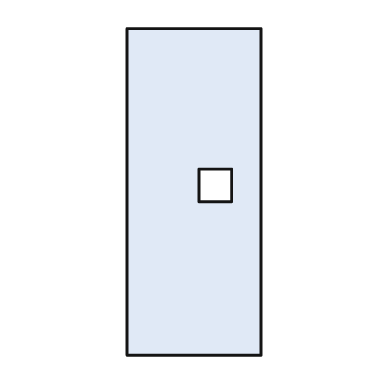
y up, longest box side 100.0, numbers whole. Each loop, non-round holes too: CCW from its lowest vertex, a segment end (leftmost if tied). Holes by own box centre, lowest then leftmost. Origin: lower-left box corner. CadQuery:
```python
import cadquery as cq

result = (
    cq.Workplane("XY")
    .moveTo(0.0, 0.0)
    .lineTo(41.0, 0.0)
    .lineTo(41.0, 100.0)
    .lineTo(0.0, 100.0)
    .close()
    .moveTo(22.0, 47.0)
    .lineTo(32.0, 47.0)
    .lineTo(32.0, 57.0)
    .lineTo(22.0, 57.0)
    .close()
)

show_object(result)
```